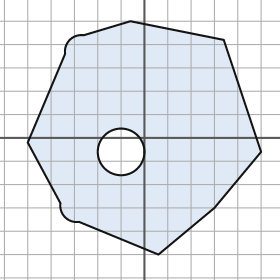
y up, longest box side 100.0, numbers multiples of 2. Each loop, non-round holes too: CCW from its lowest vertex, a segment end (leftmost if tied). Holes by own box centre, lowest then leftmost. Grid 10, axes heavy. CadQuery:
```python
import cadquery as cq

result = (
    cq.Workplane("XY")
    .moveTo(6.0, -50.0)
    .lineTo(30.0, -30.0)
    .lineTo(50.0, -6.0)
    .lineTo(34.0, 42.0)
    .lineTo(-6.0, 50.0)
    .lineTo(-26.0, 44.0)
    .threePointArc((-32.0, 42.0), (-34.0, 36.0))
    .lineTo(-50.0, -2.0)
    .lineTo(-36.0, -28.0)
    .threePointArc((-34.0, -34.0), (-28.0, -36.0))
    .close()
    .moveTo(-10.0, -6.0)
    .circle(10.0)
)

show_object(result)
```